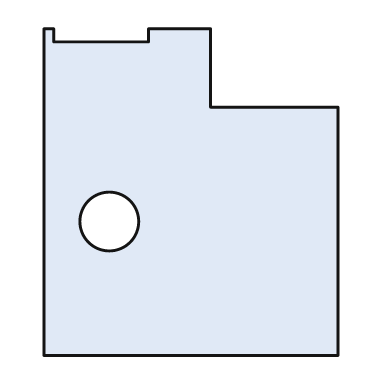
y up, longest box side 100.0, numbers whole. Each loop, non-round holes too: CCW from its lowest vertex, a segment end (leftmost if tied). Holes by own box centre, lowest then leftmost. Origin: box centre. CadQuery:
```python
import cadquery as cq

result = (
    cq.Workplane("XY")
    .moveTo(-45.0, -50.0)
    .lineTo(45.0, -50.0)
    .lineTo(45.0, 26.0)
    .lineTo(6.0, 26.0)
    .lineTo(6.0, 50.0)
    .lineTo(-13.0, 50.0)
    .lineTo(-13.0, 46.0)
    .lineTo(-42.0, 46.0)
    .lineTo(-42.0, 50.0)
    .lineTo(-45.0, 50.0)
    .close()
    .moveTo(-25.0, -9.0)
    .circle(9.0)
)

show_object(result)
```